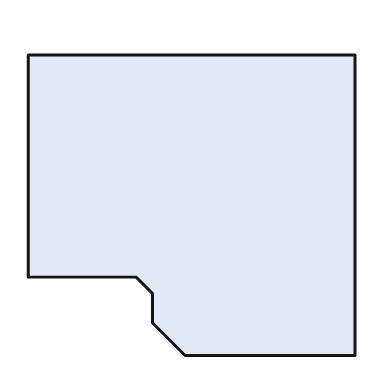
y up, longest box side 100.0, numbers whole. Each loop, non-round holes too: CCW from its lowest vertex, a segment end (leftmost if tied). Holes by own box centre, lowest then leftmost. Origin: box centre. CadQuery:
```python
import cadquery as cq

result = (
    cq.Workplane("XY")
    .moveTo(-2.0, -46.0)
    .lineTo(50.0, -46.0)
    .lineTo(50.0, 46.0)
    .lineTo(-50.0, 46.0)
    .lineTo(-50.0, -22.0)
    .lineTo(-17.0, -22.0)
    .lineTo(-12.0, -27.0)
    .lineTo(-12.0, -36.0)
    .close()
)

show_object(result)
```